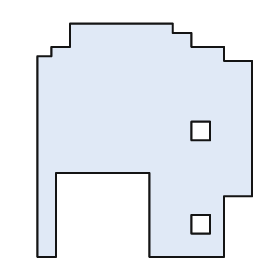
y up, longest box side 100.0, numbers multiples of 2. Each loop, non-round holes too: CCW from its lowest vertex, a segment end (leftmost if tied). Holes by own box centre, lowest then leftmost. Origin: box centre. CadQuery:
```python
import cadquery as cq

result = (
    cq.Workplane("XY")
    .moveTo(-46.0, -50.0)
    .lineTo(-38.0, -50.0)
    .lineTo(-38.0, -14.0)
    .lineTo(2.0, -14.0)
    .lineTo(2.0, -50.0)
    .lineTo(34.0, -50.0)
    .lineTo(34.0, -24.0)
    .lineTo(46.0, -24.0)
    .lineTo(46.0, 34.0)
    .lineTo(34.0, 34.0)
    .lineTo(34.0, 40.0)
    .lineTo(20.0, 40.0)
    .lineTo(20.0, 46.0)
    .lineTo(12.0, 46.0)
    .lineTo(12.0, 50.0)
    .lineTo(-32.0, 50.0)
    .lineTo(-32.0, 40.0)
    .lineTo(-40.0, 40.0)
    .lineTo(-40.0, 36.0)
    .lineTo(-46.0, 36.0)
    .close()
    .moveTo(20.0, -40.0)
    .lineTo(28.0, -40.0)
    .lineTo(28.0, -32.0)
    .lineTo(20.0, -32.0)
    .close()
    .moveTo(20.0, 0.0)
    .lineTo(28.0, 0.0)
    .lineTo(28.0, 8.0)
    .lineTo(20.0, 8.0)
    .close()
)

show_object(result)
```